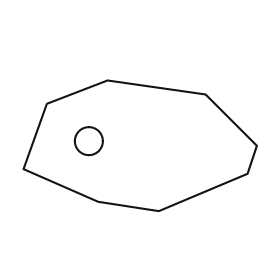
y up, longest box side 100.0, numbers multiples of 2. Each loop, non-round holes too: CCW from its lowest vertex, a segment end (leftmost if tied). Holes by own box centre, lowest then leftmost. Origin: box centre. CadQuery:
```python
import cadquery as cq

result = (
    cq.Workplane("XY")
    .moveTo(8.0, -28.0)
    .lineTo(46.0, -12.0)
    .lineTo(50.0, 0.0)
    .lineTo(28.0, 22.0)
    .lineTo(-14.0, 28.0)
    .lineTo(-40.0, 18.0)
    .lineTo(-50.0, -10.0)
    .lineTo(-18.0, -24.0)
    .close()
    .moveTo(-22.0, 2.0)
    .circle(6.0)
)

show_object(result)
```